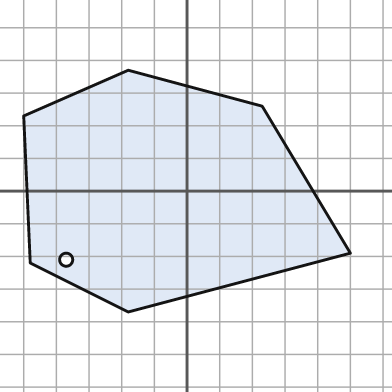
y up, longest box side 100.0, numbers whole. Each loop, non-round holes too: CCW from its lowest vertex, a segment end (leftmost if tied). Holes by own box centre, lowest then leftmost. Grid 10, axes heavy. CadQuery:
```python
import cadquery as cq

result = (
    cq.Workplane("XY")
    .moveTo(-18.0, -37.0)
    .lineTo(50.0, -19.0)
    .lineTo(23.0, 26.0)
    .lineTo(-18.0, 37.0)
    .lineTo(-50.0, 23.0)
    .lineTo(-48.0, -22.0)
    .close()
    .moveTo(-37.0, -21.0)
    .circle(2.0)
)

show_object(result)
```